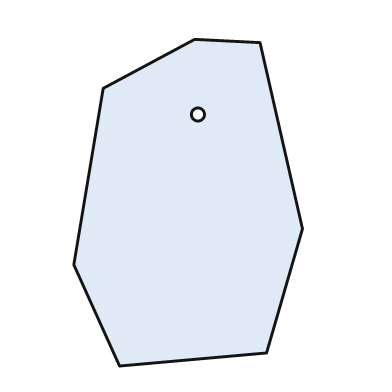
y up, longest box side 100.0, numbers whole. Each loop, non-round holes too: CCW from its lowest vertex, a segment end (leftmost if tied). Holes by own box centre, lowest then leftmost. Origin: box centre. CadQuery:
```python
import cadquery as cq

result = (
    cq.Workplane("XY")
    .moveTo(-21.0, -50.0)
    .lineTo(24.0, -46.0)
    .lineTo(35.0, -8.0)
    .lineTo(22.0, 49.0)
    .lineTo(2.0, 50.0)
    .lineTo(-26.0, 35.0)
    .lineTo(-35.0, -19.0)
    .close()
    .moveTo(3.0, 27.0)
    .circle(2.0)
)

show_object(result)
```